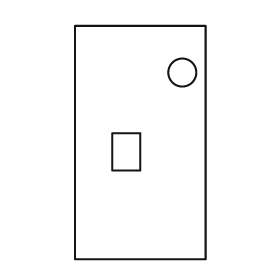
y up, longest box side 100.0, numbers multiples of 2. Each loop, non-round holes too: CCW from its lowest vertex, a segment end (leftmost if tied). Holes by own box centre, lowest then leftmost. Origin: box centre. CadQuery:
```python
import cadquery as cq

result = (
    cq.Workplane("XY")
    .moveTo(-28.0, -50.0)
    .lineTo(28.0, -50.0)
    .lineTo(28.0, 50.0)
    .lineTo(-28.0, 50.0)
    .close()
    .moveTo(-12.0, -12.0)
    .lineTo(0.0, -12.0)
    .lineTo(0.0, 4.0)
    .lineTo(-12.0, 4.0)
    .close()
    .moveTo(18.0, 30.0)
    .circle(6.0)
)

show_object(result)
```